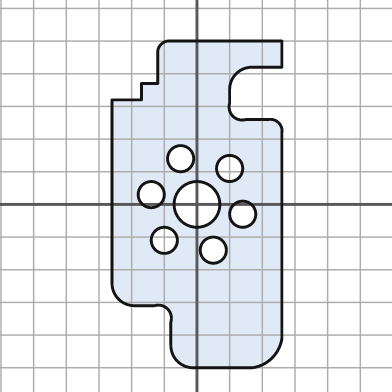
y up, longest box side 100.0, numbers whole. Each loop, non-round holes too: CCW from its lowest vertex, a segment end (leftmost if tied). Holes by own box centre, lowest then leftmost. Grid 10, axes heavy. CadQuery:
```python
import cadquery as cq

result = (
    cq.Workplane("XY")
    .moveTo(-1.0, -50.0)
    .lineTo(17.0, -50.0)
    .threePointArc((23.0, -47.0), (26.0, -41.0))
    .lineTo(26.0, 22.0)
    .threePointArc((25.0, 25.0), (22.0, 26.0))
    .lineTo(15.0, 26.0)
    .threePointArc((11.0, 27.0), (10.0, 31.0))
    .lineTo(10.0, 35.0)
    .threePointArc((12.0, 40.0), (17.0, 42.0))
    .lineTo(26.0, 42.0)
    .lineTo(26.0, 50.0)
    .lineTo(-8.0, 50.0)
    .threePointArc((-11.0, 49.0), (-12.0, 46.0))
    .lineTo(-12.0, 37.0)
    .lineTo(-17.0, 37.0)
    .lineTo(-17.0, 32.0)
    .lineTo(-26.0, 32.0)
    .lineTo(-26.0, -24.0)
    .threePointArc((-24.0, -29.0), (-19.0, -31.0))
    .lineTo(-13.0, -31.0)
    .threePointArc((-9.0, -32.0), (-8.0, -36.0))
    .lineTo(-8.0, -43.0)
    .threePointArc((-6.0, -48.0), (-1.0, -50.0))
    .close()
    .moveTo(5.0, -14.0)
    .circle(4.0)
    .moveTo(-10.0, -11.0)
    .circle(4.0)
    .moveTo(14.0, -3.0)
    .circle(4.0)
    .moveTo(0.0, 0.0)
    .circle(7.0)
    .moveTo(-14.0, 3.0)
    .circle(4.0)
    .moveTo(10.0, 11.0)
    .circle(4.0)
    .moveTo(-5.0, 14.0)
    .circle(4.0)
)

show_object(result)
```